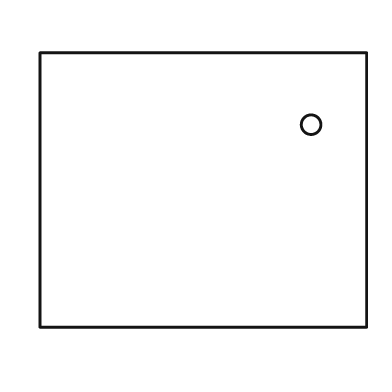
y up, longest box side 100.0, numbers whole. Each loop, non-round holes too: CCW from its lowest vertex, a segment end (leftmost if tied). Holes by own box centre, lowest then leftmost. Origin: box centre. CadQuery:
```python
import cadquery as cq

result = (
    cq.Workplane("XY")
    .moveTo(-50.0, -42.0)
    .lineTo(50.0, -42.0)
    .lineTo(50.0, 42.0)
    .lineTo(-50.0, 42.0)
    .close()
    .moveTo(33.0, 20.0)
    .circle(3.0)
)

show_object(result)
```